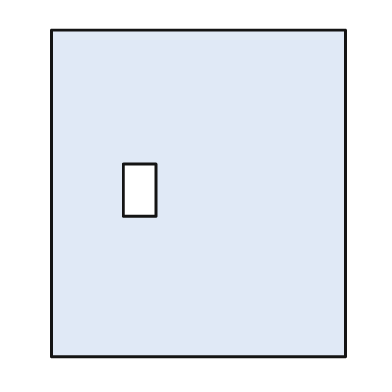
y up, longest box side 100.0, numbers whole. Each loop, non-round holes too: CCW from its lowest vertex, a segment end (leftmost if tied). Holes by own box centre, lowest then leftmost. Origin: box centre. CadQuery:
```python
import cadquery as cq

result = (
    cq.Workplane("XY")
    .moveTo(-45.0, -50.0)
    .lineTo(45.0, -50.0)
    .lineTo(45.0, 50.0)
    .lineTo(-45.0, 50.0)
    .close()
    .moveTo(-23.0, -7.0)
    .lineTo(-13.0, -7.0)
    .lineTo(-13.0, 9.0)
    .lineTo(-23.0, 9.0)
    .close()
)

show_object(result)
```